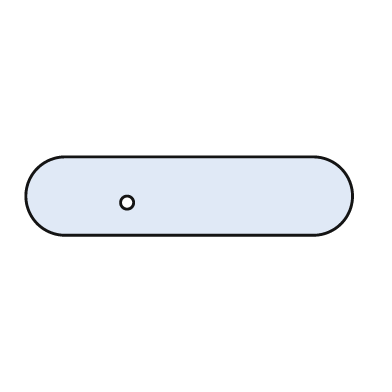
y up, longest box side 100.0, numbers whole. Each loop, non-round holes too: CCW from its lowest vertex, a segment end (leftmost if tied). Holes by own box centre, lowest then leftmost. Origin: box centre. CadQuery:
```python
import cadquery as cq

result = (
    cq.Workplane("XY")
    .moveTo(-38.0, -12.0)
    .lineTo(38.0, -12.0)
    .threePointArc((50.0, 0.0), (38.0, 12.0))
    .lineTo(-38.0, 12.0)
    .threePointArc((-50.0, 0.0), (-38.0, -12.0))
    .close()
    .moveTo(-19.0, -2.0)
    .circle(2.0)
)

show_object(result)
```